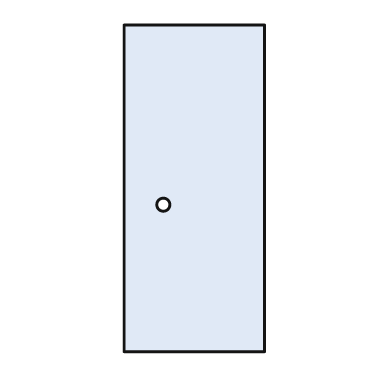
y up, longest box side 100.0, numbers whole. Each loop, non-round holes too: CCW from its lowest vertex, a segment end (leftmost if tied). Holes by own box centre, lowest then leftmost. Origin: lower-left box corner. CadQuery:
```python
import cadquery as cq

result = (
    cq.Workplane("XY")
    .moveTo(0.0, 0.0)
    .lineTo(43.0, 0.0)
    .lineTo(43.0, 100.0)
    .lineTo(0.0, 100.0)
    .close()
    .moveTo(12.0, 45.0)
    .circle(2.0)
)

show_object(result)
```